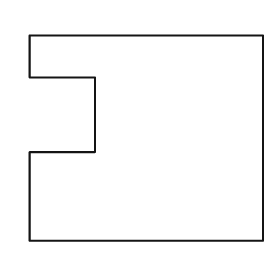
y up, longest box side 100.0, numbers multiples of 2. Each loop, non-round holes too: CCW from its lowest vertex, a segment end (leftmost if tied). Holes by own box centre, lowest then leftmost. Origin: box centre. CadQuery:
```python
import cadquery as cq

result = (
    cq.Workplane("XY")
    .moveTo(-50.0, -44.0)
    .lineTo(50.0, -44.0)
    .lineTo(50.0, 44.0)
    .lineTo(-50.0, 44.0)
    .lineTo(-50.0, 26.0)
    .lineTo(-22.0, 26.0)
    .lineTo(-22.0, -6.0)
    .lineTo(-50.0, -6.0)
    .close()
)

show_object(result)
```